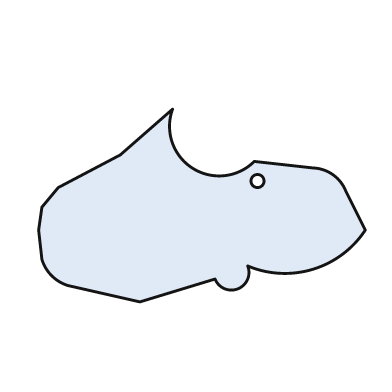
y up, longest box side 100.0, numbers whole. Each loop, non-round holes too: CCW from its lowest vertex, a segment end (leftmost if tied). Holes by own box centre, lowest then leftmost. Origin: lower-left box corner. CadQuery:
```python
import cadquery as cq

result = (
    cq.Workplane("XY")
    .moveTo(31.0, 0.0)
    .lineTo(54.0, 7.0)
    .threePointArc((61.0, 4.0), (64.0, 11.0))
    .threePointArc((84.0, 10.0), (100.0, 22.0))
    .lineTo(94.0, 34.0)
    .threePointArc((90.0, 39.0), (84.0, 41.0))
    .lineTo(66.0, 43.0)
    .threePointArc((47.0, 41.0), (41.0, 59.0))
    .lineTo(25.0, 45.0)
    .lineTo(6.0, 35.0)
    .lineTo(1.0, 29.0)
    .lineTo(0.0, 22.0)
    .lineTo(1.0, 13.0)
    .threePointArc((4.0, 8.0), (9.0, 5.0))
    .close()
    .moveTo(67.0, 37.0)
    .circle(2.0)
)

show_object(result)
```